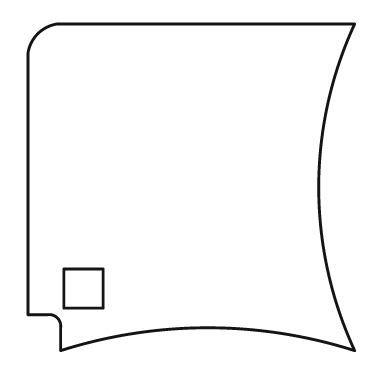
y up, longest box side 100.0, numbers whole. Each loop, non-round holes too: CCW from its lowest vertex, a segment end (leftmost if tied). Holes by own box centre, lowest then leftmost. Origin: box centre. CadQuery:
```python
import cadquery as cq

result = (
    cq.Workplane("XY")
    .moveTo(-40.0, -50.0)
    .threePointArc((5.0, -43.0), (50.0, -50.0))
    .threePointArc((39.0, 0.0), (50.0, 50.0))
    .lineTo(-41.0, 50.0)
    .threePointArc((-47.0, 47.0), (-50.0, 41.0))
    .lineTo(-50.0, -39.0)
    .lineTo(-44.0, -39.0)
    .threePointArc((-41.0, -40.0), (-40.0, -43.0))
    .close()
    .moveTo(-39.0, -37.0)
    .lineTo(-27.0, -37.0)
    .lineTo(-27.0, -25.0)
    .lineTo(-39.0, -25.0)
    .close()
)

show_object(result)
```